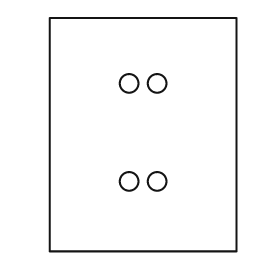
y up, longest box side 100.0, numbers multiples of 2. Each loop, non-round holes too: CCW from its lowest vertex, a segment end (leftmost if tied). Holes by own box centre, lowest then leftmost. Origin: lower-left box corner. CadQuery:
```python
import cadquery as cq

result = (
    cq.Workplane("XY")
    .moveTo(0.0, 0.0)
    .lineTo(80.0, 0.0)
    .lineTo(80.0, 100.0)
    .lineTo(0.0, 100.0)
    .close()
    .moveTo(34.0, 30.0)
    .circle(4.0)
    .moveTo(46.0, 30.0)
    .circle(4.0)
    .moveTo(34.0, 72.0)
    .circle(4.0)
    .moveTo(46.0, 72.0)
    .circle(4.0)
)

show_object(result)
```